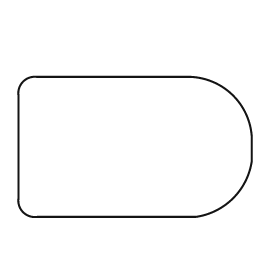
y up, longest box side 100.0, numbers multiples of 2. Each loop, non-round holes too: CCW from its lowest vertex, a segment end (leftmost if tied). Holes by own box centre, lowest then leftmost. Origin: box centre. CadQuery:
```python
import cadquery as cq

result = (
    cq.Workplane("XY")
    .moveTo(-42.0, -30.0)
    .lineTo(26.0, -30.0)
    .threePointArc((42.0, -22.0), (50.0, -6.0))
    .lineTo(50.0, 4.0)
    .threePointArc((42.0, 22.0), (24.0, 30.0))
    .lineTo(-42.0, 30.0)
    .threePointArc((-48.0, 28.0), (-50.0, 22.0))
    .lineTo(-50.0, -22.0)
    .threePointArc((-48.0, -28.0), (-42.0, -30.0))
    .close()
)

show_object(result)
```